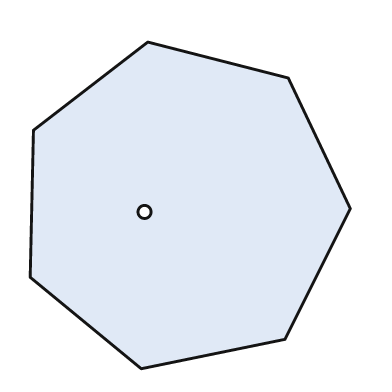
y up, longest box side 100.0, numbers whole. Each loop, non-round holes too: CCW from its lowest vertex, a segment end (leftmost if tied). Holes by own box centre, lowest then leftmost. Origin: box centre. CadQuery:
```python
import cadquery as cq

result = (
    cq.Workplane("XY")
    .moveTo(-15.0, -50.0)
    .lineTo(29.0, -41.0)
    .lineTo(49.0, -1.0)
    .lineTo(30.0, 39.0)
    .lineTo(-13.0, 50.0)
    .lineTo(-48.0, 23.0)
    .lineTo(-49.0, -22.0)
    .close()
    .moveTo(-14.0, -2.0)
    .circle(2.0)
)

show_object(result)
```